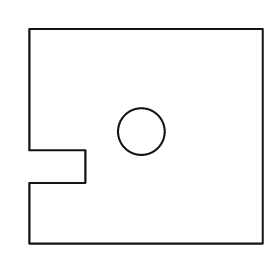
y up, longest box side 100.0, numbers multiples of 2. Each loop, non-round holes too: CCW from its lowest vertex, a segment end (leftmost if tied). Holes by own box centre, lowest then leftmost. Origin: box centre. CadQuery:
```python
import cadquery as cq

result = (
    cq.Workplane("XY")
    .moveTo(-50.0, -46.0)
    .lineTo(50.0, -46.0)
    .lineTo(50.0, 46.0)
    .lineTo(-50.0, 46.0)
    .lineTo(-50.0, -6.0)
    .lineTo(-26.0, -6.0)
    .lineTo(-26.0, -20.0)
    .lineTo(-50.0, -20.0)
    .close()
    .moveTo(-2.0, 2.0)
    .circle(10.0)
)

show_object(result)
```